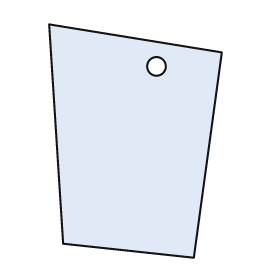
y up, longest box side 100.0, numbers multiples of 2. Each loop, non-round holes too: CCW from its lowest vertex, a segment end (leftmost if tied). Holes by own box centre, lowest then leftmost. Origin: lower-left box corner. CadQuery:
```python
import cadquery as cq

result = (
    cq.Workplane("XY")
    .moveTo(62.0, 0.0)
    .lineTo(74.0, 88.0)
    .lineTo(0.0, 100.0)
    .lineTo(6.0, 6.0)
    .close()
    .moveTo(46.0, 82.0)
    .circle(4.0)
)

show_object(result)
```